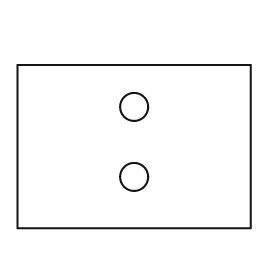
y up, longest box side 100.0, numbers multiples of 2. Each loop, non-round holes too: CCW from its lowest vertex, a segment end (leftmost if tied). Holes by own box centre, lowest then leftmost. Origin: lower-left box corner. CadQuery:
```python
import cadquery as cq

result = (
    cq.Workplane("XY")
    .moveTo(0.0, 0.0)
    .lineTo(100.0, 0.0)
    .lineTo(100.0, 70.0)
    .lineTo(0.0, 70.0)
    .close()
    .moveTo(50.0, 22.0)
    .circle(6.0)
    .moveTo(50.0, 52.0)
    .circle(6.0)
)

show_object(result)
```